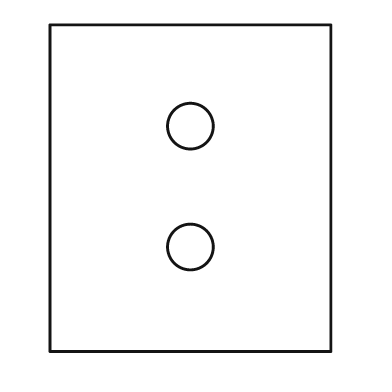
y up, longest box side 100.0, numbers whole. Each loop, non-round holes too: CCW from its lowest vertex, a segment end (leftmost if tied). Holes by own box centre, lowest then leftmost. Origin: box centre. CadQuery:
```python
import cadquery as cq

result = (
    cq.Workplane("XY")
    .moveTo(-43.0, -50.0)
    .lineTo(43.0, -50.0)
    .lineTo(43.0, 50.0)
    .lineTo(-43.0, 50.0)
    .close()
    .moveTo(0.0, -18.0)
    .circle(7.0)
    .moveTo(0.0, 19.0)
    .circle(7.0)
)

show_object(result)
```